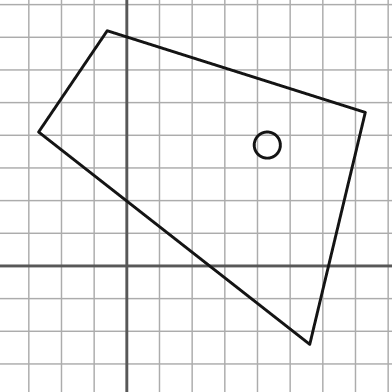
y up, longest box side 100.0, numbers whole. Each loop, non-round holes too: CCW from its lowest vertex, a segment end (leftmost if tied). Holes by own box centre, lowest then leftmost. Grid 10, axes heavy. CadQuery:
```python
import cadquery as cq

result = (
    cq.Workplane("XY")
    .moveTo(56.0, -24.0)
    .lineTo(73.0, 47.0)
    .lineTo(-6.0, 72.0)
    .lineTo(-27.0, 41.0)
    .close()
    .moveTo(43.0, 37.0)
    .circle(4.0)
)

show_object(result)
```